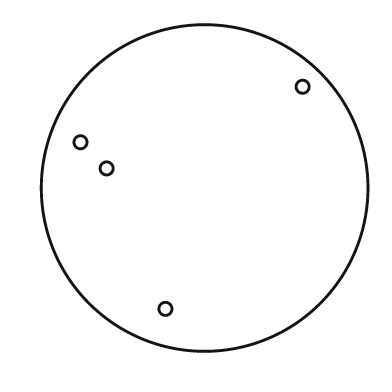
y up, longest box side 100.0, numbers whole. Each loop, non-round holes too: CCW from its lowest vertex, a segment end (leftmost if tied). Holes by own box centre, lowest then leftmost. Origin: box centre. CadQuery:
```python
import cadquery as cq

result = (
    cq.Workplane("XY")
    .moveTo(0.0, 0.0)
    .circle(50.0)
    .moveTo(-12.0, -37.0)
    .circle(2.0)
    .moveTo(-30.0, 6.0)
    .circle(2.0)
    .moveTo(-38.0, 14.0)
    .circle(2.0)
    .moveTo(30.0, 31.0)
    .circle(2.0)
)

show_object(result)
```